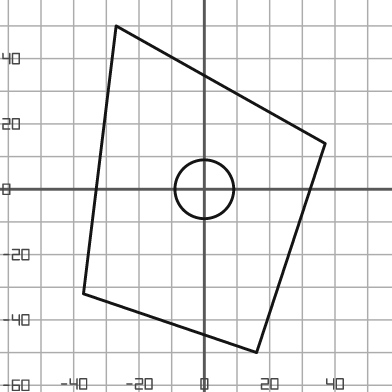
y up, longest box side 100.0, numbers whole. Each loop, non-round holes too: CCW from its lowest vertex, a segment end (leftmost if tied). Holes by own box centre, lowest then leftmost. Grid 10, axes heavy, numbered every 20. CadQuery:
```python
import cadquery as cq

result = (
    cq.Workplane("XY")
    .moveTo(16.0, -50.0)
    .lineTo(37.0, 14.0)
    .lineTo(-27.0, 50.0)
    .lineTo(-37.0, -32.0)
    .close()
    .moveTo(0.0, 0.0)
    .circle(9.0)
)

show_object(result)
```